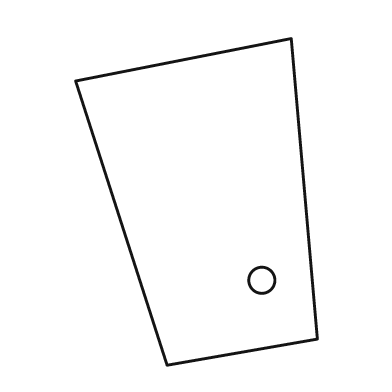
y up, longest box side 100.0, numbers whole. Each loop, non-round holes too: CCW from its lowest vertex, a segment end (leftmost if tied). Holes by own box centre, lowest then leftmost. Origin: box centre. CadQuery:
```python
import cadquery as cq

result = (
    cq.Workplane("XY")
    .moveTo(-9.0, -50.0)
    .lineTo(37.0, -42.0)
    .lineTo(29.0, 50.0)
    .lineTo(-37.0, 37.0)
    .close()
    .moveTo(20.0, -24.0)
    .circle(4.0)
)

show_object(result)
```